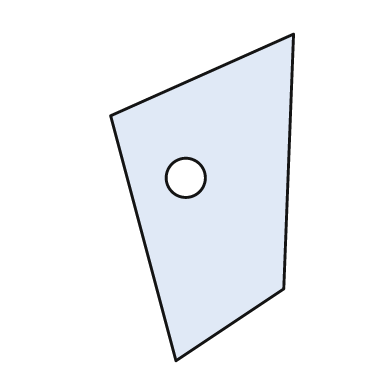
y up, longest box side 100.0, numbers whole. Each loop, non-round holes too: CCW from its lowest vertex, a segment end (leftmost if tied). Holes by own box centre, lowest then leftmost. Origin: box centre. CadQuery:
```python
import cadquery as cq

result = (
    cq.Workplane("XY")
    .moveTo(-8.0, -50.0)
    .lineTo(25.0, -28.0)
    .lineTo(28.0, 50.0)
    .lineTo(-28.0, 25.0)
    .close()
    .moveTo(-5.0, 6.0)
    .circle(6.0)
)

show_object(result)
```